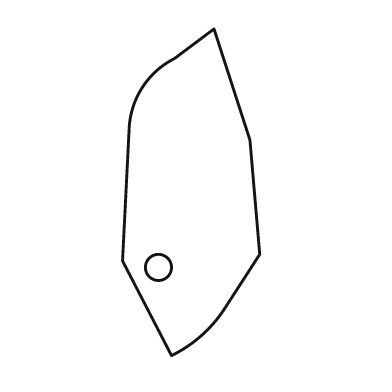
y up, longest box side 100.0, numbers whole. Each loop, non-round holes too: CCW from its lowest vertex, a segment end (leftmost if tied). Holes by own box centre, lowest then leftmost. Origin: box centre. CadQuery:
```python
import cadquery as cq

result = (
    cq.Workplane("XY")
    .moveTo(-6.0, -50.0)
    .threePointArc((3.0, -44.0), (10.0, -36.0))
    .lineTo(21.0, -19.0)
    .lineTo(18.0, 16.0)
    .lineTo(7.0, 50.0)
    .lineTo(-5.0, 41.0)
    .threePointArc((-15.0, 32.0), (-19.0, 19.0))
    .lineTo(-21.0, -21.0)
    .close()
    .moveTo(-10.0, -23.0)
    .circle(4.0)
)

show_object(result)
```